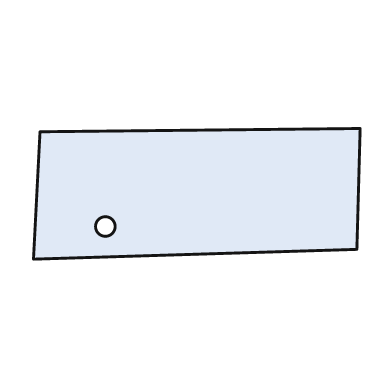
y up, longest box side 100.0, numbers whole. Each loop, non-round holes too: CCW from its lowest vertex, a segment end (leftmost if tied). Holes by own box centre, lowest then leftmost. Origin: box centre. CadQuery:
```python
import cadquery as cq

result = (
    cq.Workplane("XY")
    .moveTo(-50.0, -20.0)
    .lineTo(49.0, -17.0)
    .lineTo(50.0, 20.0)
    .lineTo(-48.0, 19.0)
    .close()
    .moveTo(-28.0, -10.0)
    .circle(3.0)
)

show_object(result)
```